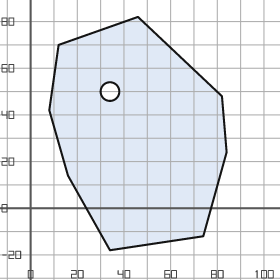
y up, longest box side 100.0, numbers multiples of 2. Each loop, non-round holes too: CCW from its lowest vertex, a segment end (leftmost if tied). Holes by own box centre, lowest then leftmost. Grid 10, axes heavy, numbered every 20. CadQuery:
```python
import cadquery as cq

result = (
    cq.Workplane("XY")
    .moveTo(34.0, -18.0)
    .lineTo(74.0, -12.0)
    .lineTo(84.0, 24.0)
    .lineTo(82.0, 48.0)
    .lineTo(46.0, 82.0)
    .lineTo(12.0, 70.0)
    .lineTo(8.0, 42.0)
    .lineTo(16.0, 14.0)
    .close()
    .moveTo(34.0, 50.0)
    .circle(4.0)
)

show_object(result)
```